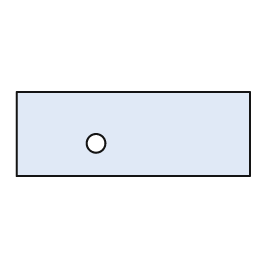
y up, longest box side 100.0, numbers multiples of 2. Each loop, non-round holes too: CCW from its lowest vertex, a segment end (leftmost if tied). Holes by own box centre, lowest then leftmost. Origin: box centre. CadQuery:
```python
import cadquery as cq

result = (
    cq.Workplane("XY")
    .moveTo(-50.0, -18.0)
    .lineTo(50.0, -18.0)
    .lineTo(50.0, 18.0)
    .lineTo(-50.0, 18.0)
    .close()
    .moveTo(-16.0, -4.0)
    .circle(4.0)
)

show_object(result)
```